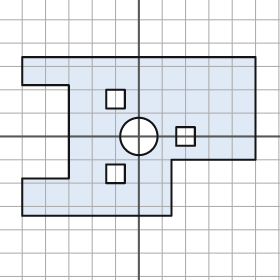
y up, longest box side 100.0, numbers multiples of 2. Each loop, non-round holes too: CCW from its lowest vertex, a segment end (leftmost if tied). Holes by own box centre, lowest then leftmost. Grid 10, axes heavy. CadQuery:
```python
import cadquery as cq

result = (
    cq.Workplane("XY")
    .moveTo(-50.0, -34.0)
    .lineTo(14.0, -34.0)
    .lineTo(14.0, -10.0)
    .lineTo(50.0, -10.0)
    .lineTo(50.0, 34.0)
    .lineTo(-50.0, 34.0)
    .lineTo(-50.0, 22.0)
    .lineTo(-30.0, 22.0)
    .lineTo(-30.0, -18.0)
    .lineTo(-50.0, -18.0)
    .close()
    .moveTo(-14.0, -20.0)
    .lineTo(-6.0, -20.0)
    .lineTo(-6.0, -12.0)
    .lineTo(-14.0, -12.0)
    .close()
    .moveTo(0.0, 0.0)
    .circle(8.0)
    .moveTo(16.0, -4.0)
    .lineTo(24.0, -4.0)
    .lineTo(24.0, 4.0)
    .lineTo(16.0, 4.0)
    .close()
    .moveTo(-14.0, 12.0)
    .lineTo(-6.0, 12.0)
    .lineTo(-6.0, 20.0)
    .lineTo(-14.0, 20.0)
    .close()
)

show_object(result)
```